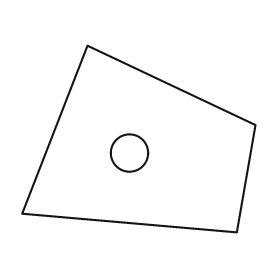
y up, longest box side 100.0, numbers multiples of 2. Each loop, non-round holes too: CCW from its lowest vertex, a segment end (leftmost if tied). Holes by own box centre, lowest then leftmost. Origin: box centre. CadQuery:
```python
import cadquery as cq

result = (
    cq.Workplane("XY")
    .moveTo(42.0, -40.0)
    .lineTo(50.0, 6.0)
    .lineTo(-22.0, 40.0)
    .lineTo(-50.0, -32.0)
    .close()
    .moveTo(-4.0, -6.0)
    .circle(8.0)
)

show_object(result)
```